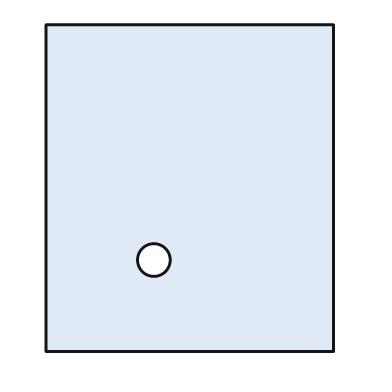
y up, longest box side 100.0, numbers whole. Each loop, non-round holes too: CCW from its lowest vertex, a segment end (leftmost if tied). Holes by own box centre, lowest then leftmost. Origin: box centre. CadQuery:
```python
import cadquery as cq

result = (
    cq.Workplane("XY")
    .moveTo(-44.0, -50.0)
    .lineTo(44.0, -50.0)
    .lineTo(44.0, 50.0)
    .lineTo(-44.0, 50.0)
    .close()
    .moveTo(-11.0, -22.0)
    .circle(5.0)
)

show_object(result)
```